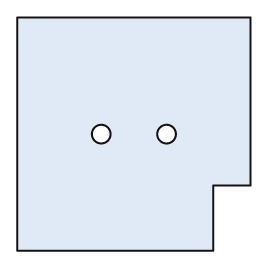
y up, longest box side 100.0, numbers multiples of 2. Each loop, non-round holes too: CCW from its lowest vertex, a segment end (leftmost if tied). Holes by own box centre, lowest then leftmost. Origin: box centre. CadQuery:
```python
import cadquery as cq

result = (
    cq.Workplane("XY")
    .moveTo(-50.0, -50.0)
    .lineTo(34.0, -50.0)
    .lineTo(34.0, -22.0)
    .lineTo(50.0, -22.0)
    .lineTo(50.0, 50.0)
    .lineTo(-50.0, 50.0)
    .close()
    .moveTo(-14.0, 0.0)
    .circle(4.0)
    .moveTo(14.0, 0.0)
    .circle(4.0)
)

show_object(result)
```